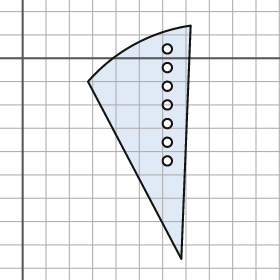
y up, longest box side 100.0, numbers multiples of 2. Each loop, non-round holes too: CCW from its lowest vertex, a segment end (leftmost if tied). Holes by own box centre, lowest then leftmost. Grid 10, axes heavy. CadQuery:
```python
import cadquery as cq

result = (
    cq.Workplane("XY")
    .moveTo(68.0, -86.0)
    .lineTo(72.0, 14.0)
    .threePointArc((48.0, 6.0), (28.0, -10.0))
    .close()
    .moveTo(62.0, -44.0)
    .circle(2.0)
    .moveTo(62.0, -36.0)
    .circle(2.0)
    .moveTo(62.0, -28.0)
    .circle(2.0)
    .moveTo(62.0, -20.0)
    .circle(2.0)
    .moveTo(62.0, -12.0)
    .circle(2.0)
    .moveTo(62.0, -4.0)
    .circle(2.0)
    .moveTo(62.0, 4.0)
    .circle(2.0)
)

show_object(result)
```